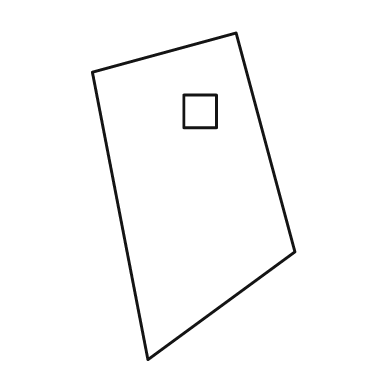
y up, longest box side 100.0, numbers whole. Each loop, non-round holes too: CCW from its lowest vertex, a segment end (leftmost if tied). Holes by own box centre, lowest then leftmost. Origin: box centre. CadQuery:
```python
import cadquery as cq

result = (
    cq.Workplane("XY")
    .moveTo(-14.0, -50.0)
    .lineTo(31.0, -17.0)
    .lineTo(13.0, 50.0)
    .lineTo(-31.0, 38.0)
    .close()
    .moveTo(-3.0, 21.0)
    .lineTo(7.0, 21.0)
    .lineTo(7.0, 31.0)
    .lineTo(-3.0, 31.0)
    .close()
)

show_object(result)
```